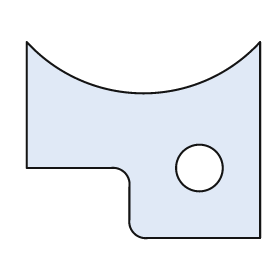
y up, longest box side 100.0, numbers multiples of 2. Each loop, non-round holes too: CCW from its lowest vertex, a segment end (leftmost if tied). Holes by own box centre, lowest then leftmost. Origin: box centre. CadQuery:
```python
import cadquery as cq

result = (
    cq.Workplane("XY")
    .moveTo(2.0, -42.0)
    .lineTo(50.0, -42.0)
    .lineTo(50.0, 42.0)
    .threePointArc((0.0, 20.0), (-50.0, 42.0))
    .lineTo(-50.0, -12.0)
    .lineTo(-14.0, -12.0)
    .threePointArc((-8.0, -14.0), (-6.0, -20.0))
    .lineTo(-6.0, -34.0)
    .threePointArc((-4.0, -40.0), (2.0, -42.0))
    .close()
    .moveTo(24.0, -12.0)
    .circle(10.0)
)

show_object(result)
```